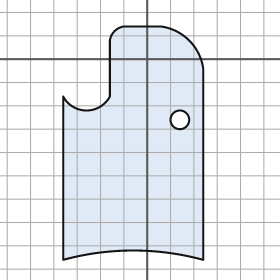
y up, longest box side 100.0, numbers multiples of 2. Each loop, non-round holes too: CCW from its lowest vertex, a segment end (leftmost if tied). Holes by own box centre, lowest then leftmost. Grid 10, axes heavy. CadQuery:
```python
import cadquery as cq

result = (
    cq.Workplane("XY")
    .moveTo(-36.0, -86.0)
    .threePointArc((-6.0, -82.0), (24.0, -86.0))
    .lineTo(24.0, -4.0)
    .threePointArc((18.0, 8.0), (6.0, 14.0))
    .lineTo(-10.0, 14.0)
    .threePointArc((-14.0, 12.0), (-16.0, 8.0))
    .lineTo(-16.0, -16.0)
    .threePointArc((-26.0, -22.0), (-36.0, -16.0))
    .close()
    .moveTo(14.0, -26.0)
    .circle(4.0)
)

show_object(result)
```